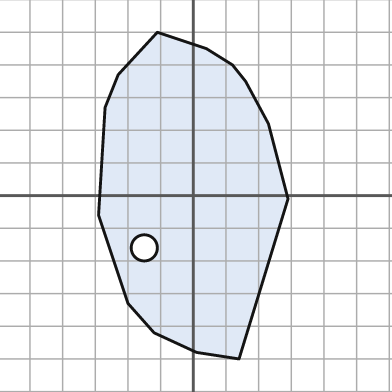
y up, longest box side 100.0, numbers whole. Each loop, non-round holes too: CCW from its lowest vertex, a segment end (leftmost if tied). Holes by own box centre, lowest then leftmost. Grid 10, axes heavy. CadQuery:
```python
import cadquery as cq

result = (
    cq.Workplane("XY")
    .moveTo(14.0, -50.0)
    .lineTo(29.0, -1.0)
    .lineTo(23.0, 22.0)
    .lineTo(16.0, 35.0)
    .lineTo(12.0, 40.0)
    .lineTo(4.0, 45.0)
    .lineTo(-11.0, 50.0)
    .lineTo(-23.0, 37.0)
    .lineTo(-27.0, 27.0)
    .lineTo(-29.0, -6.0)
    .lineTo(-20.0, -33.0)
    .lineTo(-12.0, -42.0)
    .lineTo(1.0, -48.0)
    .close()
    .moveTo(-15.0, -16.0)
    .circle(4.0)
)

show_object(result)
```